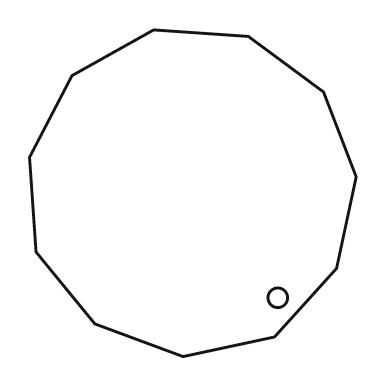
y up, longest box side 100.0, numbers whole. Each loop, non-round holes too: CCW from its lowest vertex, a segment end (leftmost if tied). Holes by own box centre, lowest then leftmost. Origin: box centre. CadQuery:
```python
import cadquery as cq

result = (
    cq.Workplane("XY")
    .moveTo(-3.0, -50.0)
    .lineTo(25.0, -44.0)
    .lineTo(44.0, -23.0)
    .lineTo(50.0, 5.0)
    .lineTo(40.0, 31.0)
    .lineTo(17.0, 48.0)
    .lineTo(-12.0, 50.0)
    .lineTo(-37.0, 36.0)
    .lineTo(-50.0, 11.0)
    .lineTo(-48.0, -18.0)
    .lineTo(-30.0, -40.0)
    .close()
    .moveTo(26.0, -32.0)
    .circle(3.0)
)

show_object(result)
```